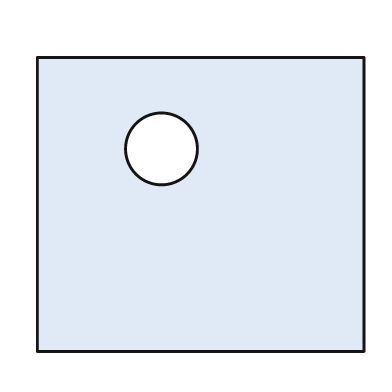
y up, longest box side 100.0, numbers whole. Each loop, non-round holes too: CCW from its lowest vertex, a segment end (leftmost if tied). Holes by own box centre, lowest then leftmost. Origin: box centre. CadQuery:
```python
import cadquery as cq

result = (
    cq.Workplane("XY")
    .moveTo(-50.0, -45.0)
    .lineTo(50.0, -45.0)
    .lineTo(50.0, 45.0)
    .lineTo(-50.0, 45.0)
    .close()
    .moveTo(-12.0, 17.0)
    .circle(11.0)
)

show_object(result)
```